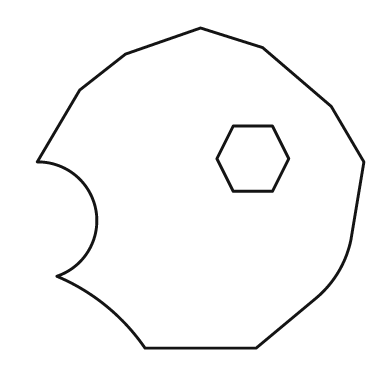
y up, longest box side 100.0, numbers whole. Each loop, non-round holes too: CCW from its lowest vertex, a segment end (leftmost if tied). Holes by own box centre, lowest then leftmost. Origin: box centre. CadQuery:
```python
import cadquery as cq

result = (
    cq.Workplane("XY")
    .moveTo(-17.0, -49.0)
    .lineTo(17.0, -49.0)
    .lineTo(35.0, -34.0)
    .threePointArc((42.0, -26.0), (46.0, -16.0))
    .lineTo(50.0, 8.0)
    .lineTo(40.0, 25.0)
    .lineTo(19.0, 43.0)
    .lineTo(0.0, 49.0)
    .lineTo(-23.0, 41.0)
    .lineTo(-37.0, 30.0)
    .lineTo(-50.0, 8.0)
    .threePointArc((-32.0, -7.0), (-44.0, -27.0))
    .threePointArc((-29.0, -36.0), (-17.0, -49.0))
    .close()
    .moveTo(10.0, -1.0)
    .lineTo(22.0, -1.0)
    .lineTo(27.0, 9.0)
    .lineTo(22.0, 19.0)
    .lineTo(10.0, 19.0)
    .lineTo(5.0, 9.0)
    .close()
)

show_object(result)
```